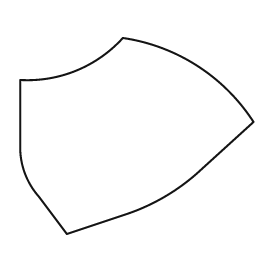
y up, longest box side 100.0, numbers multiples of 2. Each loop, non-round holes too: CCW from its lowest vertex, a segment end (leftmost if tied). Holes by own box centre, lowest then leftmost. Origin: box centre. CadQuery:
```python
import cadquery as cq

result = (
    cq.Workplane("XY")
    .moveTo(-30.0, -42.0)
    .lineTo(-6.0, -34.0)
    .threePointArc((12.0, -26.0), (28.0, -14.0))
    .lineTo(50.0, 6.0)
    .threePointArc((26.0, 30.0), (-6.0, 42.0))
    .threePointArc((-26.0, 28.0), (-50.0, 24.0))
    .lineTo(-50.0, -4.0)
    .threePointArc((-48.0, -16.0), (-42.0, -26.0))
    .close()
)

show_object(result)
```